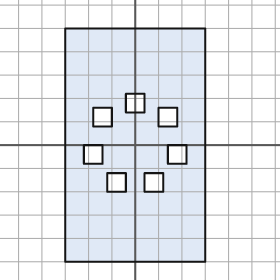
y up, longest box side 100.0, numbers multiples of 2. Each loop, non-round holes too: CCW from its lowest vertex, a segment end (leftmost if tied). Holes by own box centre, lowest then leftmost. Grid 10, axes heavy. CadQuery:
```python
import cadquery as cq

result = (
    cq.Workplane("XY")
    .moveTo(-30.0, -50.0)
    .lineTo(30.0, -50.0)
    .lineTo(30.0, 50.0)
    .lineTo(-30.0, 50.0)
    .close()
    .moveTo(-12.0, -20.0)
    .lineTo(-4.0, -20.0)
    .lineTo(-4.0, -12.0)
    .lineTo(-12.0, -12.0)
    .close()
    .moveTo(4.0, -20.0)
    .lineTo(12.0, -20.0)
    .lineTo(12.0, -12.0)
    .lineTo(4.0, -12.0)
    .close()
    .moveTo(-22.0, -8.0)
    .lineTo(-14.0, -8.0)
    .lineTo(-14.0, 0.0)
    .lineTo(-22.0, 0.0)
    .close()
    .moveTo(14.0, -8.0)
    .lineTo(22.0, -8.0)
    .lineTo(22.0, 0.0)
    .lineTo(14.0, 0.0)
    .close()
    .moveTo(-18.0, 8.0)
    .lineTo(-10.0, 8.0)
    .lineTo(-10.0, 16.0)
    .lineTo(-18.0, 16.0)
    .close()
    .moveTo(10.0, 8.0)
    .lineTo(18.0, 8.0)
    .lineTo(18.0, 16.0)
    .lineTo(10.0, 16.0)
    .close()
    .moveTo(-4.0, 14.0)
    .lineTo(4.0, 14.0)
    .lineTo(4.0, 22.0)
    .lineTo(-4.0, 22.0)
    .close()
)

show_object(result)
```